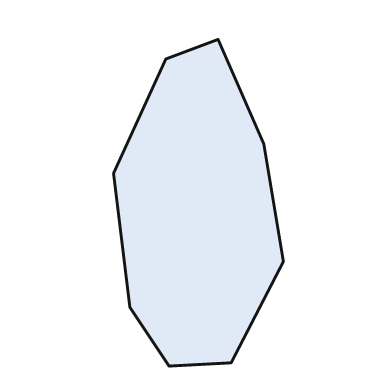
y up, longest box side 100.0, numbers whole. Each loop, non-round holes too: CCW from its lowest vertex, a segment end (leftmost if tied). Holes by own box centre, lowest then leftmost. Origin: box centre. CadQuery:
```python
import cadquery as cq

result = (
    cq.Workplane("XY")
    .moveTo(-9.0, -50.0)
    .lineTo(10.0, -49.0)
    .lineTo(26.0, -18.0)
    .lineTo(20.0, 18.0)
    .lineTo(6.0, 50.0)
    .lineTo(-10.0, 44.0)
    .lineTo(-26.0, 9.0)
    .lineTo(-21.0, -32.0)
    .close()
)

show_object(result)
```